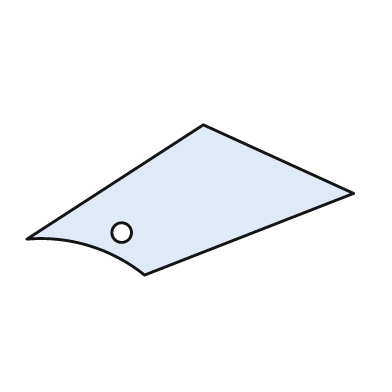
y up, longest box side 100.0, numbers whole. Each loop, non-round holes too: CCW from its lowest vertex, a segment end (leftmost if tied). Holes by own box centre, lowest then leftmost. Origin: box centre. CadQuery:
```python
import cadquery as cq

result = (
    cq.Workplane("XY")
    .moveTo(-14.0, -23.0)
    .lineTo(50.0, 2.0)
    .lineTo(4.0, 23.0)
    .lineTo(-50.0, -12.0)
    .threePointArc((-31.0, -14.0), (-14.0, -23.0))
    .close()
    .moveTo(-21.0, -10.0)
    .circle(3.0)
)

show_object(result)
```